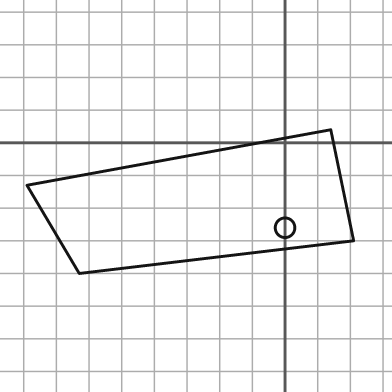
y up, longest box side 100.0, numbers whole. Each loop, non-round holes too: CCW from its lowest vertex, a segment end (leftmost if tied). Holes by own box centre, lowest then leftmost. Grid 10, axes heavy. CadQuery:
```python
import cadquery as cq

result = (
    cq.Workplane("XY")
    .moveTo(-63.0, -40.0)
    .lineTo(21.0, -30.0)
    .lineTo(14.0, 4.0)
    .lineTo(-79.0, -13.0)
    .close()
    .moveTo(0.0, -26.0)
    .circle(3.0)
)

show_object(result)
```